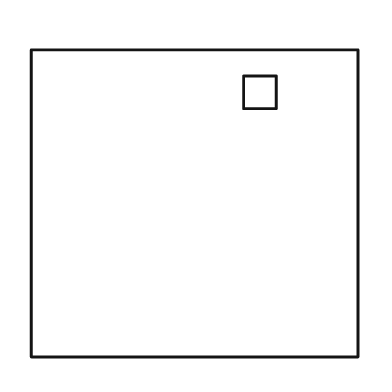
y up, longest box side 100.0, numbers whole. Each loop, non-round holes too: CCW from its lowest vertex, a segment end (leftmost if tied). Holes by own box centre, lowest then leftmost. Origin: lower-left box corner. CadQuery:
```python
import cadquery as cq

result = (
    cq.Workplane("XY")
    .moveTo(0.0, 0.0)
    .lineTo(100.0, 0.0)
    .lineTo(100.0, 94.0)
    .lineTo(0.0, 94.0)
    .close()
    .moveTo(65.0, 76.0)
    .lineTo(75.0, 76.0)
    .lineTo(75.0, 86.0)
    .lineTo(65.0, 86.0)
    .close()
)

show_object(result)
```